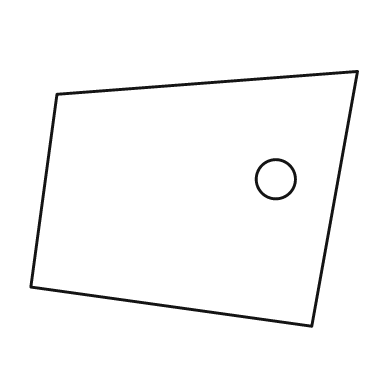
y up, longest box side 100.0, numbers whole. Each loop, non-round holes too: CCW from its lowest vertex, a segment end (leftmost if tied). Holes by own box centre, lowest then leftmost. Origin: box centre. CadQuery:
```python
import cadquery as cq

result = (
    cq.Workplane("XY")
    .moveTo(36.0, -39.0)
    .lineTo(50.0, 39.0)
    .lineTo(-42.0, 32.0)
    .lineTo(-50.0, -27.0)
    .close()
    .moveTo(25.0, 6.0)
    .circle(6.0)
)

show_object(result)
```